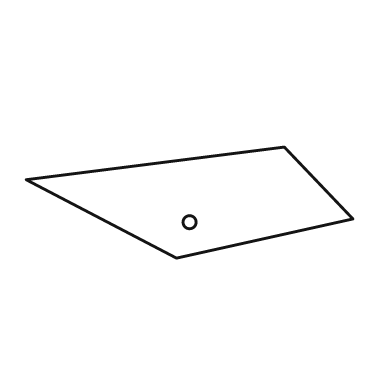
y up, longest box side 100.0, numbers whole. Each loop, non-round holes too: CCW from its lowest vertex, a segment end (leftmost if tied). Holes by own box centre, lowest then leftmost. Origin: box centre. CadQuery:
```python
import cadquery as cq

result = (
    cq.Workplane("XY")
    .moveTo(-4.0, -17.0)
    .lineTo(50.0, -5.0)
    .lineTo(29.0, 17.0)
    .lineTo(-50.0, 7.0)
    .close()
    .moveTo(0.0, -6.0)
    .circle(2.0)
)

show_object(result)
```